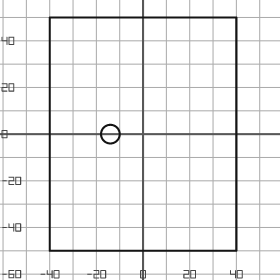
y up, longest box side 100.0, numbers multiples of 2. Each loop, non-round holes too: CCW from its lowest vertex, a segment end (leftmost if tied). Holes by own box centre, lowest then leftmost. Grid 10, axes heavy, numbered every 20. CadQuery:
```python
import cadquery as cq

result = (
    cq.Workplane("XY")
    .moveTo(-40.0, -50.0)
    .lineTo(40.0, -50.0)
    .lineTo(40.0, 50.0)
    .lineTo(-40.0, 50.0)
    .close()
    .moveTo(-14.0, 0.0)
    .circle(4.0)
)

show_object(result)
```